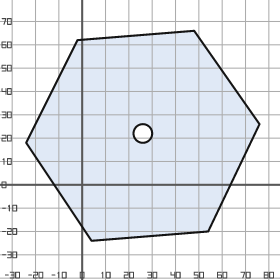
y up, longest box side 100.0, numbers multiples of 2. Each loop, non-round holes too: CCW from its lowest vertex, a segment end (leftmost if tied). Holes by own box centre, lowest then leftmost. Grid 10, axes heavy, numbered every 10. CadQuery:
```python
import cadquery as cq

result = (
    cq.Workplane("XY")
    .moveTo(4.0, -24.0)
    .lineTo(54.0, -20.0)
    .lineTo(76.0, 26.0)
    .lineTo(48.0, 66.0)
    .lineTo(-2.0, 62.0)
    .lineTo(-24.0, 18.0)
    .close()
    .moveTo(26.0, 22.0)
    .circle(4.0)
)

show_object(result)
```